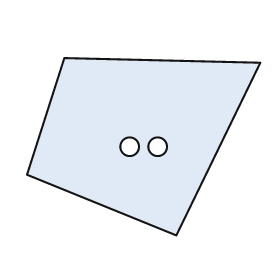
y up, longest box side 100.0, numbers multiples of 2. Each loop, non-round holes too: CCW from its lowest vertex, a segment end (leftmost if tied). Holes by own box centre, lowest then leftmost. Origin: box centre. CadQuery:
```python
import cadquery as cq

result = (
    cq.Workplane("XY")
    .moveTo(14.0, -38.0)
    .lineTo(50.0, 36.0)
    .lineTo(-34.0, 38.0)
    .lineTo(-50.0, -12.0)
    .close()
    .moveTo(-6.0, 0.0)
    .circle(4.0)
    .moveTo(6.0, 0.0)
    .circle(4.0)
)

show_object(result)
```